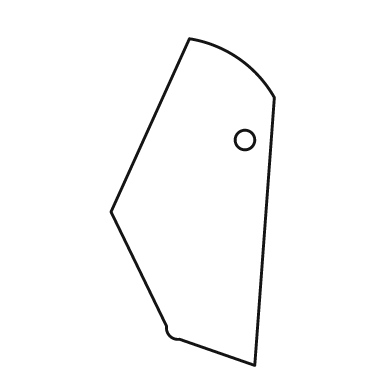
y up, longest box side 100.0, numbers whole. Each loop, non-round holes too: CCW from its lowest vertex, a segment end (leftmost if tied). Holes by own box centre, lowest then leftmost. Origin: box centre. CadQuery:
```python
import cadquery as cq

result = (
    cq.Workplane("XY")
    .moveTo(19.0, -50.0)
    .lineTo(25.0, 32.0)
    .threePointArc((14.0, 44.0), (-1.0, 50.0))
    .lineTo(-25.0, -3.0)
    .lineTo(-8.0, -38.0)
    .threePointArc((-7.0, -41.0), (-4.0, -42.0))
    .close()
    .moveTo(16.0, 19.0)
    .circle(3.0)
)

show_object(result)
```